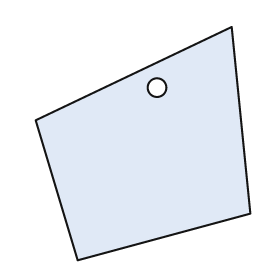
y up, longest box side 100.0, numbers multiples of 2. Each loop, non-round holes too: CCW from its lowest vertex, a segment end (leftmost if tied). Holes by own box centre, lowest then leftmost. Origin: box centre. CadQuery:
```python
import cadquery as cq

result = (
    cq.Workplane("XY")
    .moveTo(-28.0, -50.0)
    .lineTo(46.0, -30.0)
    .lineTo(38.0, 50.0)
    .lineTo(-46.0, 10.0)
    .close()
    .moveTo(6.0, 24.0)
    .circle(4.0)
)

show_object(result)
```